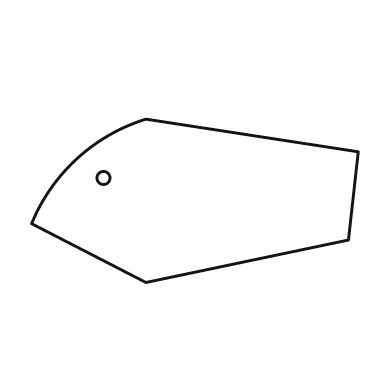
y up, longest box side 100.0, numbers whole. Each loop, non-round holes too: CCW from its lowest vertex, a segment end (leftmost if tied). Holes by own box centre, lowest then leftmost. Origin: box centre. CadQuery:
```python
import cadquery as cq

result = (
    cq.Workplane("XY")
    .moveTo(-15.0, -25.0)
    .lineTo(47.0, -12.0)
    .lineTo(50.0, 15.0)
    .lineTo(-15.0, 25.0)
    .threePointArc((-36.0, 13.0), (-50.0, -7.0))
    .close()
    .moveTo(-28.0, 7.0)
    .circle(2.0)
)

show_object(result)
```